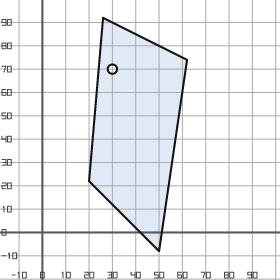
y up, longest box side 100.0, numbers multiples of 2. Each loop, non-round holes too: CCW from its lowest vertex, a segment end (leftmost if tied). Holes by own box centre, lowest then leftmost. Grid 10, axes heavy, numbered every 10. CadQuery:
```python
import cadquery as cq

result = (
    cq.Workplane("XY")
    .moveTo(50.0, -8.0)
    .lineTo(62.0, 74.0)
    .lineTo(26.0, 92.0)
    .lineTo(20.0, 22.0)
    .close()
    .moveTo(30.0, 70.0)
    .circle(2.0)
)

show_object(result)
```